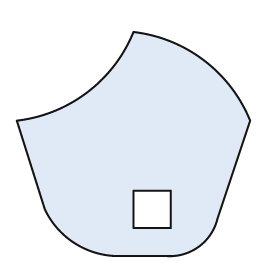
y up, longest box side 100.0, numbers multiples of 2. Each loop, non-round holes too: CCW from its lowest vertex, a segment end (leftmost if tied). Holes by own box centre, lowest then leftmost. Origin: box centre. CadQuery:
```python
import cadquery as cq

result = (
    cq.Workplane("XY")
    .moveTo(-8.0, -48.0)
    .lineTo(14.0, -48.0)
    .threePointArc((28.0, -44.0), (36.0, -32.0))
    .lineTo(50.0, 10.0)
    .threePointArc((30.0, 36.0), (0.0, 48.0))
    .threePointArc((-20.0, 22.0), (-50.0, 10.0))
    .lineTo(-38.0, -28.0)
    .threePointArc((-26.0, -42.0), (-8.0, -48.0))
    .close()
    .moveTo(0.0, -36.0)
    .lineTo(16.0, -36.0)
    .lineTo(16.0, -20.0)
    .lineTo(0.0, -20.0)
    .close()
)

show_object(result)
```